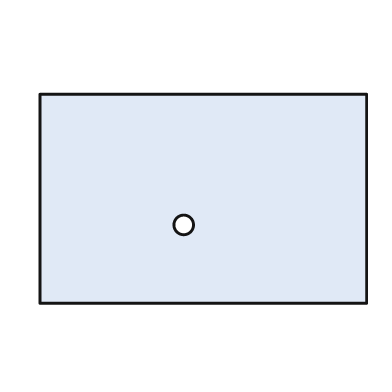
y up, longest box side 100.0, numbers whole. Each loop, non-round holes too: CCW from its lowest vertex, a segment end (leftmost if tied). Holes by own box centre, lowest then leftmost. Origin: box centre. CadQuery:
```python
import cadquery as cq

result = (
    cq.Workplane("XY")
    .moveTo(-50.0, -32.0)
    .lineTo(50.0, -32.0)
    .lineTo(50.0, 32.0)
    .lineTo(-50.0, 32.0)
    .close()
    .moveTo(-6.0, -8.0)
    .circle(3.0)
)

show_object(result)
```